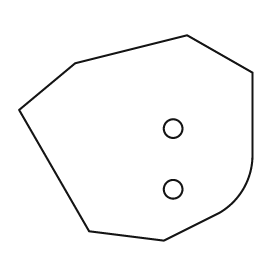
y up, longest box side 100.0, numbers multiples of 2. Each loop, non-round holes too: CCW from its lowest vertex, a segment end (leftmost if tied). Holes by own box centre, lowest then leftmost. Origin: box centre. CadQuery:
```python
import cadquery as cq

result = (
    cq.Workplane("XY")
    .moveTo(12.0, -44.0)
    .lineTo(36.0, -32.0)
    .threePointArc((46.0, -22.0), (50.0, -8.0))
    .lineTo(50.0, 28.0)
    .lineTo(22.0, 44.0)
    .lineTo(-26.0, 32.0)
    .lineTo(-50.0, 12.0)
    .lineTo(-20.0, -40.0)
    .close()
    .moveTo(16.0, -22.0)
    .circle(4.0)
    .moveTo(16.0, 4.0)
    .circle(4.0)
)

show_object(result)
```